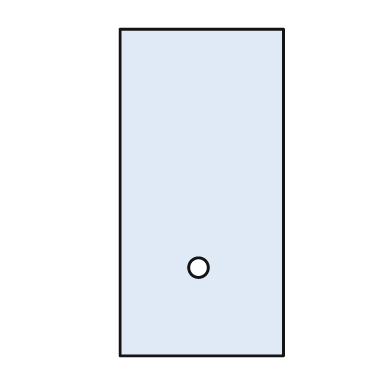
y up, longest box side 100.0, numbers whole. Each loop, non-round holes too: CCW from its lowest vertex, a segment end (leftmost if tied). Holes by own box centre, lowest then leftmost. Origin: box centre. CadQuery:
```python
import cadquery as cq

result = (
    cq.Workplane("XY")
    .moveTo(-25.0, -50.0)
    .lineTo(25.0, -50.0)
    .lineTo(25.0, 50.0)
    .lineTo(-25.0, 50.0)
    .close()
    .moveTo(-1.0, -23.0)
    .circle(3.0)
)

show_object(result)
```